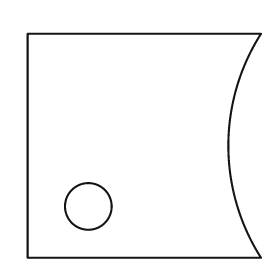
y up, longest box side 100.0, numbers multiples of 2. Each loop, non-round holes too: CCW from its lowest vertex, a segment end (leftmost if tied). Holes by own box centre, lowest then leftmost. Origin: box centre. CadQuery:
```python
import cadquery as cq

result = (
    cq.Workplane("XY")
    .moveTo(-50.0, -48.0)
    .lineTo(50.0, -48.0)
    .threePointArc((36.0, 0.0), (50.0, 48.0))
    .lineTo(-50.0, 48.0)
    .close()
    .moveTo(-24.0, -26.0)
    .circle(10.0)
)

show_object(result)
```